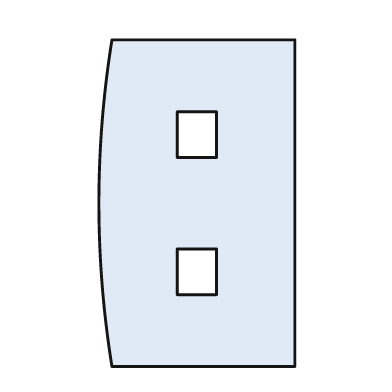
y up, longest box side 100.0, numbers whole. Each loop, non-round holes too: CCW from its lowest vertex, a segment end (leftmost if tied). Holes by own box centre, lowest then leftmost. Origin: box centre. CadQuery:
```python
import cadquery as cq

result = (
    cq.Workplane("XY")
    .moveTo(-26.0, -50.0)
    .lineTo(30.0, -50.0)
    .lineTo(30.0, 50.0)
    .lineTo(-26.0, 50.0)
    .threePointArc((-30.0, 0.0), (-26.0, -50.0))
    .close()
    .moveTo(-6.0, -28.0)
    .lineTo(6.0, -28.0)
    .lineTo(6.0, -14.0)
    .lineTo(-6.0, -14.0)
    .close()
    .moveTo(-6.0, 14.0)
    .lineTo(6.0, 14.0)
    .lineTo(6.0, 28.0)
    .lineTo(-6.0, 28.0)
    .close()
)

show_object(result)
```